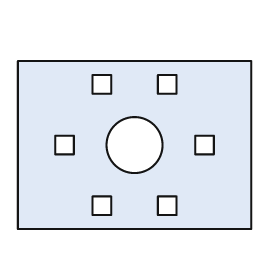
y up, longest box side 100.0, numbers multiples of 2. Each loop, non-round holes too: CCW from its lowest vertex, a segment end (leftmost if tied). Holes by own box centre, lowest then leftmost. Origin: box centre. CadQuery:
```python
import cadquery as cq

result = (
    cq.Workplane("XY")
    .moveTo(-50.0, -36.0)
    .lineTo(50.0, -36.0)
    .lineTo(50.0, 36.0)
    .lineTo(-50.0, 36.0)
    .close()
    .moveTo(-18.0, -30.0)
    .lineTo(-10.0, -30.0)
    .lineTo(-10.0, -22.0)
    .lineTo(-18.0, -22.0)
    .close()
    .moveTo(10.0, -30.0)
    .lineTo(18.0, -30.0)
    .lineTo(18.0, -22.0)
    .lineTo(10.0, -22.0)
    .close()
    .moveTo(-34.0, -4.0)
    .lineTo(-26.0, -4.0)
    .lineTo(-26.0, 4.0)
    .lineTo(-34.0, 4.0)
    .close()
    .moveTo(0.0, 0.0)
    .circle(12.0)
    .moveTo(26.0, -4.0)
    .lineTo(34.0, -4.0)
    .lineTo(34.0, 4.0)
    .lineTo(26.0, 4.0)
    .close()
    .moveTo(-18.0, 22.0)
    .lineTo(-10.0, 22.0)
    .lineTo(-10.0, 30.0)
    .lineTo(-18.0, 30.0)
    .close()
    .moveTo(10.0, 22.0)
    .lineTo(18.0, 22.0)
    .lineTo(18.0, 30.0)
    .lineTo(10.0, 30.0)
    .close()
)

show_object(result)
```